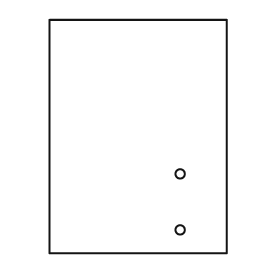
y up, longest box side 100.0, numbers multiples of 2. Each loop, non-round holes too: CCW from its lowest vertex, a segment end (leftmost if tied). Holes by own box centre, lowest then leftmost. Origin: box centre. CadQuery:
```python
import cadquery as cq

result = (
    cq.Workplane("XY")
    .moveTo(-38.0, -50.0)
    .lineTo(38.0, -50.0)
    .lineTo(38.0, 50.0)
    .lineTo(-38.0, 50.0)
    .close()
    .moveTo(18.0, -40.0)
    .circle(2.0)
    .moveTo(18.0, -16.0)
    .circle(2.0)
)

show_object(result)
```